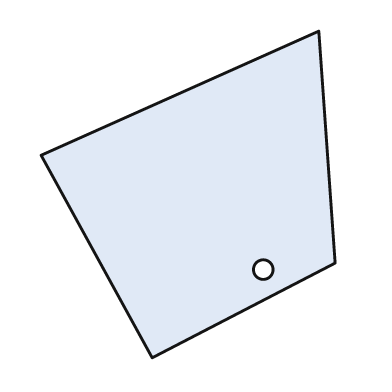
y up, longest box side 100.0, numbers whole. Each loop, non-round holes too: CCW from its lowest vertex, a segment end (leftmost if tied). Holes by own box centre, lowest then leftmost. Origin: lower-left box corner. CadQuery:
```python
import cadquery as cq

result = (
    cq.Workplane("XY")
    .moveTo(34.0, 0.0)
    .lineTo(90.0, 29.0)
    .lineTo(85.0, 100.0)
    .lineTo(0.0, 62.0)
    .close()
    .moveTo(68.0, 27.0)
    .circle(3.0)
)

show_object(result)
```